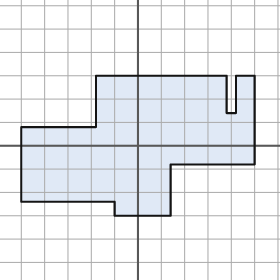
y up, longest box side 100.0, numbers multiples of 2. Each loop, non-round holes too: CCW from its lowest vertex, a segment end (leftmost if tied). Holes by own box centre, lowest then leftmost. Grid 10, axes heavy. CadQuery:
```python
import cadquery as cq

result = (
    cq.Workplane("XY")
    .moveTo(-10.0, -30.0)
    .lineTo(14.0, -30.0)
    .lineTo(14.0, -8.0)
    .lineTo(50.0, -8.0)
    .lineTo(50.0, 30.0)
    .lineTo(42.0, 30.0)
    .lineTo(42.0, 14.0)
    .lineTo(38.0, 14.0)
    .lineTo(38.0, 30.0)
    .lineTo(-18.0, 30.0)
    .lineTo(-18.0, 8.0)
    .lineTo(-50.0, 8.0)
    .lineTo(-50.0, -24.0)
    .lineTo(-10.0, -24.0)
    .close()
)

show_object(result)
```